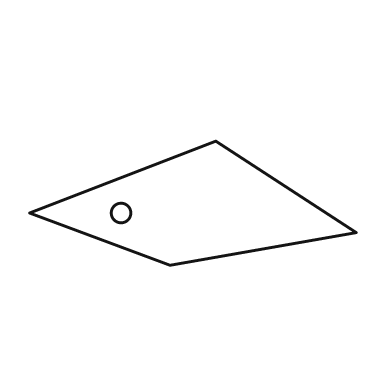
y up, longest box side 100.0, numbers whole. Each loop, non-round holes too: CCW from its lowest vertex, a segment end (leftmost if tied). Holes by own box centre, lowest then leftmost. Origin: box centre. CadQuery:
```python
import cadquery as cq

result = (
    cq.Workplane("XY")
    .moveTo(-7.0, -19.0)
    .lineTo(50.0, -9.0)
    .lineTo(7.0, 19.0)
    .lineTo(-50.0, -3.0)
    .close()
    .moveTo(-22.0, -3.0)
    .circle(3.0)
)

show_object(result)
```